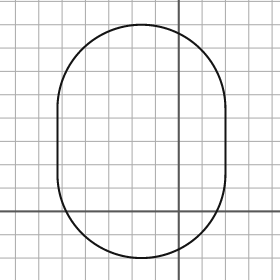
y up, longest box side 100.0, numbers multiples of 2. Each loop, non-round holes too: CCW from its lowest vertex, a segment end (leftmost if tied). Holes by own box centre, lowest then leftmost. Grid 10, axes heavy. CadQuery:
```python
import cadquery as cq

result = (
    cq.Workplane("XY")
    .moveTo(-52.0, 16.0)
    .threePointArc((-16.0, -20.0), (20.0, 16.0))
    .lineTo(20.0, 44.0)
    .threePointArc((-16.0, 80.0), (-52.0, 44.0))
    .close()
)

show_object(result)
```